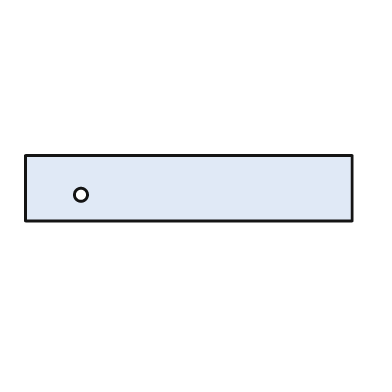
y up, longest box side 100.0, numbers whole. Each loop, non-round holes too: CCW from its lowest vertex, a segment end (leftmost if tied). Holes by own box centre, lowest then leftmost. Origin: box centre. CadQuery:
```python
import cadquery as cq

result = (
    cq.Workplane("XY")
    .moveTo(-50.0, -10.0)
    .lineTo(50.0, -10.0)
    .lineTo(50.0, 10.0)
    .lineTo(-50.0, 10.0)
    .close()
    .moveTo(-33.0, -2.0)
    .circle(2.0)
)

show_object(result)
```